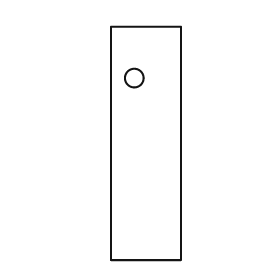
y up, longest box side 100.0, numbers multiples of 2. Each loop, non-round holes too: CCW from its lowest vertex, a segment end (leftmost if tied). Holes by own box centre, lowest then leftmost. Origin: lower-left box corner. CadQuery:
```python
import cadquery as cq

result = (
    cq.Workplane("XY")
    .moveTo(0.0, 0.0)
    .lineTo(30.0, 0.0)
    .lineTo(30.0, 100.0)
    .lineTo(0.0, 100.0)
    .close()
    .moveTo(10.0, 78.0)
    .circle(4.0)
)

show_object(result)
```